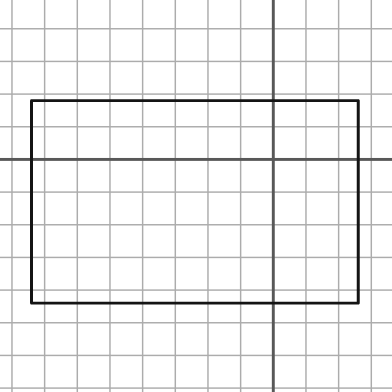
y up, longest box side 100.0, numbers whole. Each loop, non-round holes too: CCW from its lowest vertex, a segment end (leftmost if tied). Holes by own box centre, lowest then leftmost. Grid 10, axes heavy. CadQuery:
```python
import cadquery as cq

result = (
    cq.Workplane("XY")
    .moveTo(-74.0, -44.0)
    .lineTo(26.0, -44.0)
    .lineTo(26.0, 18.0)
    .lineTo(-74.0, 18.0)
    .close()
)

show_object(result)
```